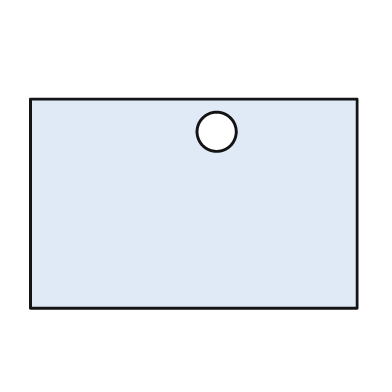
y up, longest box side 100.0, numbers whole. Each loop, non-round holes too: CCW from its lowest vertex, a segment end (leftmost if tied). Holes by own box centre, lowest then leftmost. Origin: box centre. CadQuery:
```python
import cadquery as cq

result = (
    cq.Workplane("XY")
    .moveTo(-50.0, -32.0)
    .lineTo(50.0, -32.0)
    .lineTo(50.0, 32.0)
    .lineTo(-50.0, 32.0)
    .close()
    .moveTo(7.0, 22.0)
    .circle(6.0)
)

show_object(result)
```